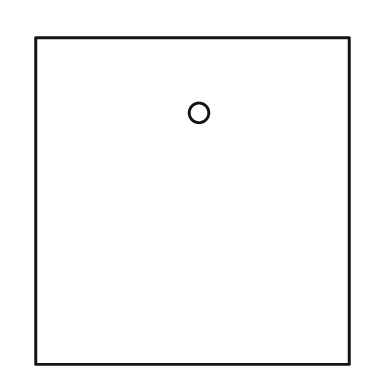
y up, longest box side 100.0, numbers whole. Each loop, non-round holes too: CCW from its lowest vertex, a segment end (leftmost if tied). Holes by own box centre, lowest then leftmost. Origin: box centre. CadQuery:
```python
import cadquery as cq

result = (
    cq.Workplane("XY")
    .moveTo(-48.0, -50.0)
    .lineTo(48.0, -50.0)
    .lineTo(48.0, 50.0)
    .lineTo(-48.0, 50.0)
    .close()
    .moveTo(2.0, 27.0)
    .circle(3.0)
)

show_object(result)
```